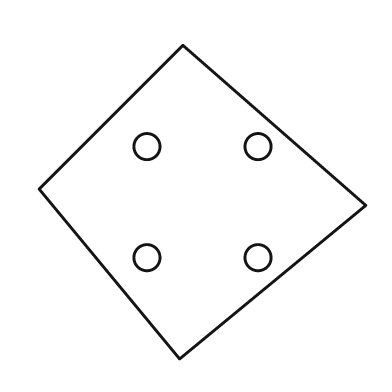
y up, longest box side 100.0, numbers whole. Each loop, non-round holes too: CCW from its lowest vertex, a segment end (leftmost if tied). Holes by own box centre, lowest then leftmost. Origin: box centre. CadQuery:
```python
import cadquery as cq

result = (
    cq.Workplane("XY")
    .moveTo(-7.0, -48.0)
    .lineTo(50.0, -1.0)
    .lineTo(-6.0, 48.0)
    .lineTo(-50.0, 4.0)
    .close()
    .moveTo(-17.0, -17.0)
    .circle(4.0)
    .moveTo(17.0, -17.0)
    .circle(4.0)
    .moveTo(-17.0, 17.0)
    .circle(4.0)
    .moveTo(17.0, 17.0)
    .circle(4.0)
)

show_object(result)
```